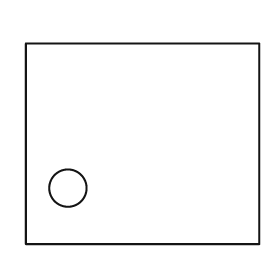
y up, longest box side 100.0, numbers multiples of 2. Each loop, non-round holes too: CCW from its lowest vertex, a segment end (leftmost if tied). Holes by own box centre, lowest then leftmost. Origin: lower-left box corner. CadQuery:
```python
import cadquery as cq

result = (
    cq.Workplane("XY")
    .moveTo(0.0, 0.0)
    .lineTo(100.0, 0.0)
    .lineTo(100.0, 86.0)
    .lineTo(0.0, 86.0)
    .close()
    .moveTo(18.0, 24.0)
    .circle(8.0)
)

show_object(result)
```